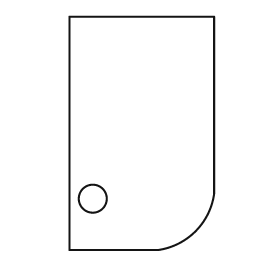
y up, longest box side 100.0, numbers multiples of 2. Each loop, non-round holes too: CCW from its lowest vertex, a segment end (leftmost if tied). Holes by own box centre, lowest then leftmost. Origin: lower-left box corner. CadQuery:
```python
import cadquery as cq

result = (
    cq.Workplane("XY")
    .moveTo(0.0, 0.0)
    .lineTo(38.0, 0.0)
    .threePointArc((54.0, 8.0), (62.0, 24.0))
    .lineTo(62.0, 100.0)
    .lineTo(0.0, 100.0)
    .close()
    .moveTo(10.0, 22.0)
    .circle(6.0)
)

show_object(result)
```